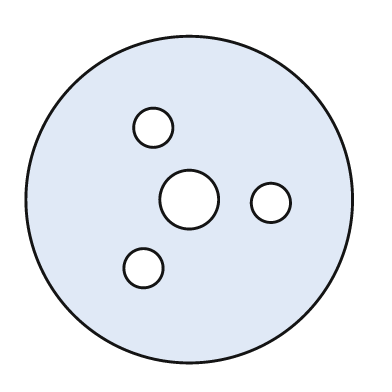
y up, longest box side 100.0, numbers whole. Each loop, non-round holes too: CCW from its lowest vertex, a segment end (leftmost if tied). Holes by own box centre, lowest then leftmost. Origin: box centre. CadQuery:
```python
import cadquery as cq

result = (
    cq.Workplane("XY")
    .moveTo(0.0, 0.0)
    .circle(50.0)
    .moveTo(-14.0, -21.0)
    .circle(6.0)
    .moveTo(25.0, -1.0)
    .circle(6.0)
    .moveTo(0.0, 0.0)
    .circle(9.0)
    .moveTo(-11.0, 22.0)
    .circle(6.0)
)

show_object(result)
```